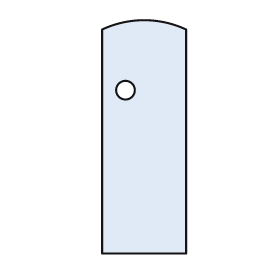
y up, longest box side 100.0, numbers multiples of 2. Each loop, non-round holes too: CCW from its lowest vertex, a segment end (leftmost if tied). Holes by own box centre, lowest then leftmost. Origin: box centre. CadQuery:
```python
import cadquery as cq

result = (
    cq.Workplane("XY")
    .moveTo(-18.0, -50.0)
    .lineTo(18.0, -50.0)
    .lineTo(18.0, 46.0)
    .threePointArc((0.0, 50.0), (-18.0, 46.0))
    .close()
    .moveTo(-8.0, 20.0)
    .circle(4.0)
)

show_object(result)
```